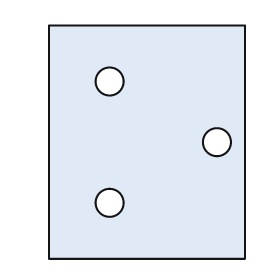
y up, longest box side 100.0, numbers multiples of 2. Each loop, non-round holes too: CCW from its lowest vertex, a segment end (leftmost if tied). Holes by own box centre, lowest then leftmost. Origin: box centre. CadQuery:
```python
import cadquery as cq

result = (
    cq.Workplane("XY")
    .moveTo(-42.0, -50.0)
    .lineTo(42.0, -50.0)
    .lineTo(42.0, 50.0)
    .lineTo(-42.0, 50.0)
    .close()
    .moveTo(-16.0, -26.0)
    .circle(6.0)
    .moveTo(30.0, 0.0)
    .circle(6.0)
    .moveTo(-16.0, 26.0)
    .circle(6.0)
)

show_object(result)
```